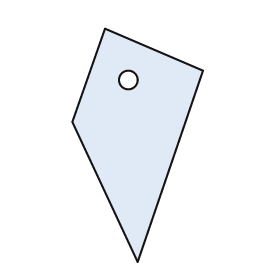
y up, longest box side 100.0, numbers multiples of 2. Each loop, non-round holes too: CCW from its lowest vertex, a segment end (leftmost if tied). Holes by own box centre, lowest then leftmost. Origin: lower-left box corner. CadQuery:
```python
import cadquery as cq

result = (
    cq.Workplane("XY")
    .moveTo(28.0, 0.0)
    .lineTo(56.0, 82.0)
    .lineTo(14.0, 100.0)
    .lineTo(0.0, 60.0)
    .close()
    .moveTo(24.0, 78.0)
    .circle(4.0)
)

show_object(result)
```